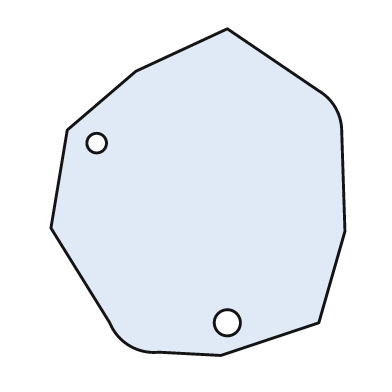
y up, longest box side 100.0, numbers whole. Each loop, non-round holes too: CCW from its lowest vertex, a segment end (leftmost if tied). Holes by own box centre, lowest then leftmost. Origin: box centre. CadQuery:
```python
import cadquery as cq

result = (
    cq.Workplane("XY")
    .moveTo(7.0, -50.0)
    .lineTo(37.0, -40.0)
    .lineTo(45.0, -12.0)
    .lineTo(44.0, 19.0)
    .threePointArc((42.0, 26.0), (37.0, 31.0))
    .lineTo(9.0, 50.0)
    .lineTo(-19.0, 37.0)
    .lineTo(-40.0, 19.0)
    .lineTo(-45.0, -11.0)
    .lineTo(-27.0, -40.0)
    .threePointArc((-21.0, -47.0), (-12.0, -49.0))
    .close()
    .moveTo(9.0, -40.0)
    .circle(4.0)
    .moveTo(-31.0, 15.0)
    .circle(3.0)
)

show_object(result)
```